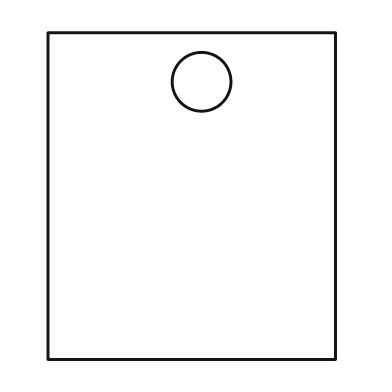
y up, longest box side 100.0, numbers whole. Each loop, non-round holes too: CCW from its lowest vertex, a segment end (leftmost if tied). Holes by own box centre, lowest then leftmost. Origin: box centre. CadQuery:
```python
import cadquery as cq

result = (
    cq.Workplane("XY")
    .moveTo(-44.0, -50.0)
    .lineTo(44.0, -50.0)
    .lineTo(44.0, 50.0)
    .lineTo(-44.0, 50.0)
    .close()
    .moveTo(3.0, 35.0)
    .circle(9.0)
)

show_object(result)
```